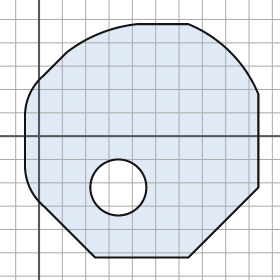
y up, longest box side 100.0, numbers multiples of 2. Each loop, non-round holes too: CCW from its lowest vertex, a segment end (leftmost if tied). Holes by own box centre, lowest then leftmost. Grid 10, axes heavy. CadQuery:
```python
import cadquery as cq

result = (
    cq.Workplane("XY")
    .moveTo(24.0, -52.0)
    .lineTo(64.0, -52.0)
    .lineTo(94.0, -22.0)
    .lineTo(94.0, 18.0)
    .threePointArc((82.0, 36.0), (64.0, 48.0))
    .lineTo(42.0, 48.0)
    .threePointArc((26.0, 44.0), (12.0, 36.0))
    .lineTo(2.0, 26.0)
    .threePointArc((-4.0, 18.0), (-6.0, 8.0))
    .lineTo(-6.0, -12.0)
    .threePointArc((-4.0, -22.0), (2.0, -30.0))
    .close()
    .moveTo(34.0, -22.0)
    .circle(12.0)
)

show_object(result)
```